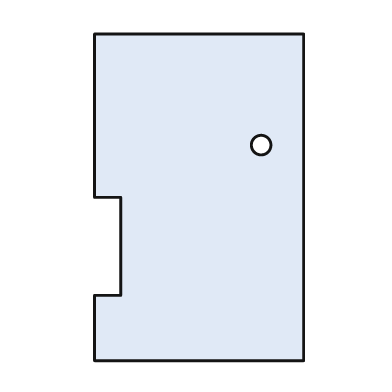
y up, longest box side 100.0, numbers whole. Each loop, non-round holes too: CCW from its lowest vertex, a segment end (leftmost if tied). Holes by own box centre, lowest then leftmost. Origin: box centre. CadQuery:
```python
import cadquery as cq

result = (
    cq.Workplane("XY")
    .moveTo(-32.0, -50.0)
    .lineTo(32.0, -50.0)
    .lineTo(32.0, 50.0)
    .lineTo(-32.0, 50.0)
    .lineTo(-32.0, 0.0)
    .lineTo(-24.0, 0.0)
    .lineTo(-24.0, -30.0)
    .lineTo(-32.0, -30.0)
    .close()
    .moveTo(19.0, 16.0)
    .circle(3.0)
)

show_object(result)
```